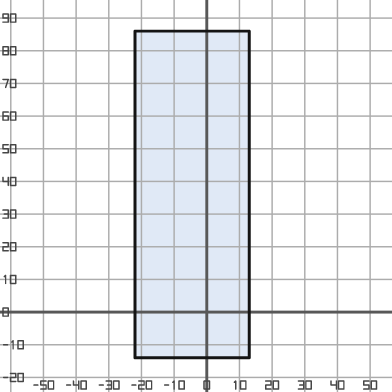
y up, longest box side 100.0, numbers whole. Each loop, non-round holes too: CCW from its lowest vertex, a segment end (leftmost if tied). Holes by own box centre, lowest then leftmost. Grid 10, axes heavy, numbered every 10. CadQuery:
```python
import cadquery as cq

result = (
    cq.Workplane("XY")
    .moveTo(-22.0, -14.0)
    .lineTo(13.0, -14.0)
    .lineTo(13.0, 86.0)
    .lineTo(-22.0, 86.0)
    .close()
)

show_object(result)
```